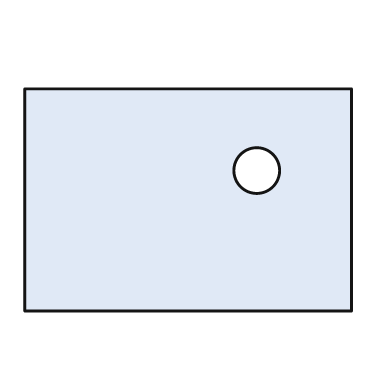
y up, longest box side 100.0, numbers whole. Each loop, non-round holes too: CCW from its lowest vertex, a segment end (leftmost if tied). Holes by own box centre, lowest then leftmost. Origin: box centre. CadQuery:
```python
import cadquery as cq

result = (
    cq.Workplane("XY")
    .moveTo(-50.0, -34.0)
    .lineTo(50.0, -34.0)
    .lineTo(50.0, 34.0)
    .lineTo(-50.0, 34.0)
    .close()
    .moveTo(21.0, 9.0)
    .circle(7.0)
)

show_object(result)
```